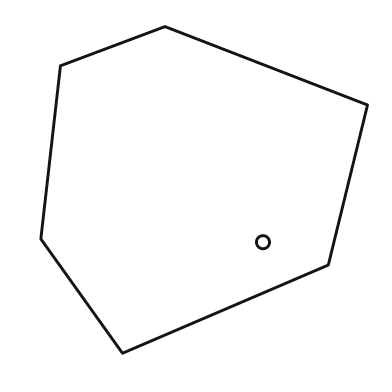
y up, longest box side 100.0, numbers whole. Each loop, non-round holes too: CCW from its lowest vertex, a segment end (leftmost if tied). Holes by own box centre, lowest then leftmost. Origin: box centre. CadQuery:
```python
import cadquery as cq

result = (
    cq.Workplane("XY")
    .moveTo(-25.0, -50.0)
    .lineTo(38.0, -23.0)
    .lineTo(50.0, 26.0)
    .lineTo(-12.0, 50.0)
    .lineTo(-44.0, 38.0)
    .lineTo(-50.0, -15.0)
    .close()
    .moveTo(18.0, -16.0)
    .circle(2.0)
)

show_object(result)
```